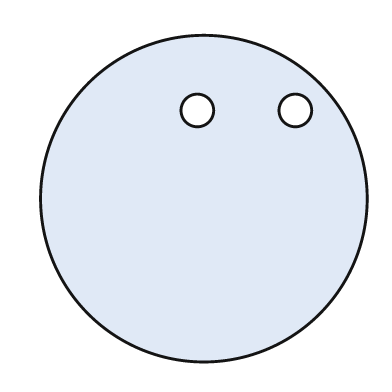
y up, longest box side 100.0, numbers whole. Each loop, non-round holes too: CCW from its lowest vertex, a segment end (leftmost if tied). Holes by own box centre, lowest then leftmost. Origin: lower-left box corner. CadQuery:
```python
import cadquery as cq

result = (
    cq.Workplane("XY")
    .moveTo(50.0, 50.0)
    .circle(50.0)
    .moveTo(48.0, 77.0)
    .circle(5.0)
    .moveTo(78.0, 77.0)
    .circle(5.0)
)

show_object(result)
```